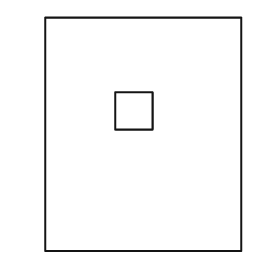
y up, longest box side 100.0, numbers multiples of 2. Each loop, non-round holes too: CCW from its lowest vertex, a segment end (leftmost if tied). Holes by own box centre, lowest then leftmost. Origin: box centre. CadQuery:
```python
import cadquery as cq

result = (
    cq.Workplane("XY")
    .moveTo(-42.0, -50.0)
    .lineTo(42.0, -50.0)
    .lineTo(42.0, 50.0)
    .lineTo(-42.0, 50.0)
    .close()
    .moveTo(-12.0, 2.0)
    .lineTo(4.0, 2.0)
    .lineTo(4.0, 18.0)
    .lineTo(-12.0, 18.0)
    .close()
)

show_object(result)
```